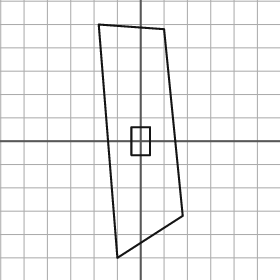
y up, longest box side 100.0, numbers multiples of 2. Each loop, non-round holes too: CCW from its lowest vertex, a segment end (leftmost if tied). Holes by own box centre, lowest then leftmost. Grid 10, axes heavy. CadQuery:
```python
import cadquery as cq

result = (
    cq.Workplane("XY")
    .moveTo(-10.0, -50.0)
    .lineTo(18.0, -32.0)
    .lineTo(10.0, 48.0)
    .lineTo(-18.0, 50.0)
    .close()
    .moveTo(-4.0, -6.0)
    .lineTo(4.0, -6.0)
    .lineTo(4.0, 6.0)
    .lineTo(-4.0, 6.0)
    .close()
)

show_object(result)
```